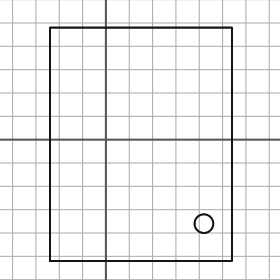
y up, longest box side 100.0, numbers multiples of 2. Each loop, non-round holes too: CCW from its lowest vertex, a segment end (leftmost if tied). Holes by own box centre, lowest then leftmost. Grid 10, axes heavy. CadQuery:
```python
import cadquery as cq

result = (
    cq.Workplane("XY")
    .moveTo(-24.0, -52.0)
    .lineTo(54.0, -52.0)
    .lineTo(54.0, 48.0)
    .lineTo(-24.0, 48.0)
    .close()
    .moveTo(42.0, -36.0)
    .circle(4.0)
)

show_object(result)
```